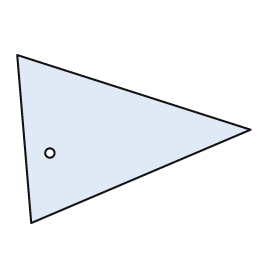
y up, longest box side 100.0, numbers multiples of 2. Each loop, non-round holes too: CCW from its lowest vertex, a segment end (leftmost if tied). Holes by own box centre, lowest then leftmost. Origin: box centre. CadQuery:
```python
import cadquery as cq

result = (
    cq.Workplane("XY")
    .moveTo(-44.0, -36.0)
    .lineTo(50.0, 4.0)
    .lineTo(-50.0, 36.0)
    .close()
    .moveTo(-36.0, -6.0)
    .circle(2.0)
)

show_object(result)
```